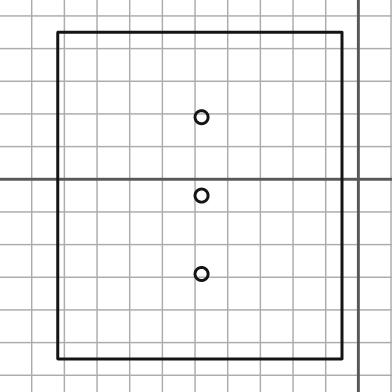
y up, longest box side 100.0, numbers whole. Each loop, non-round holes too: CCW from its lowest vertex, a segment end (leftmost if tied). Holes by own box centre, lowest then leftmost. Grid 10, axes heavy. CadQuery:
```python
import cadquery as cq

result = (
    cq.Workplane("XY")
    .moveTo(-92.0, -55.0)
    .lineTo(-5.0, -55.0)
    .lineTo(-5.0, 45.0)
    .lineTo(-92.0, 45.0)
    .close()
    .moveTo(-48.0, -29.0)
    .circle(2.0)
    .moveTo(-48.0, -5.0)
    .circle(2.0)
    .moveTo(-48.0, 19.0)
    .circle(2.0)
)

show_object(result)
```